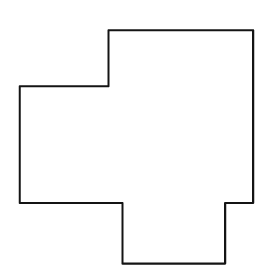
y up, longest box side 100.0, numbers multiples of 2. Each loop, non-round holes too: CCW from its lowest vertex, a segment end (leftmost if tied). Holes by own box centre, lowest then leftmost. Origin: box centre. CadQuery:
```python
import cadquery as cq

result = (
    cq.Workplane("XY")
    .moveTo(-6.0, -50.0)
    .lineTo(38.0, -50.0)
    .lineTo(38.0, -24.0)
    .lineTo(50.0, -24.0)
    .lineTo(50.0, 50.0)
    .lineTo(-12.0, 50.0)
    .lineTo(-12.0, 26.0)
    .lineTo(-50.0, 26.0)
    .lineTo(-50.0, -24.0)
    .lineTo(-6.0, -24.0)
    .close()
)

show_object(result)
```